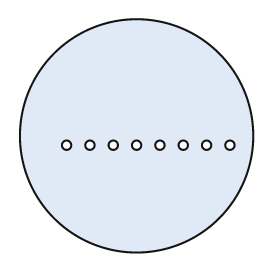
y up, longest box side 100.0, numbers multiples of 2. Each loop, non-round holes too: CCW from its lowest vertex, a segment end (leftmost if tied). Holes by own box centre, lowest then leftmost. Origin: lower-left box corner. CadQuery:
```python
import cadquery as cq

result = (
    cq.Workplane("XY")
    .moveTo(50.0, 50.0)
    .circle(50.0)
    .moveTo(20.0, 46.0)
    .circle(2.0)
    .moveTo(30.0, 46.0)
    .circle(2.0)
    .moveTo(40.0, 46.0)
    .circle(2.0)
    .moveTo(50.0, 46.0)
    .circle(2.0)
    .moveTo(60.0, 46.0)
    .circle(2.0)
    .moveTo(70.0, 46.0)
    .circle(2.0)
    .moveTo(80.0, 46.0)
    .circle(2.0)
    .moveTo(90.0, 46.0)
    .circle(2.0)
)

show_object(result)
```